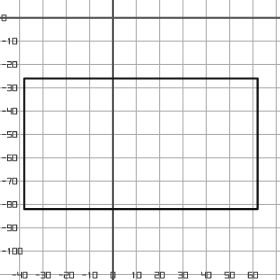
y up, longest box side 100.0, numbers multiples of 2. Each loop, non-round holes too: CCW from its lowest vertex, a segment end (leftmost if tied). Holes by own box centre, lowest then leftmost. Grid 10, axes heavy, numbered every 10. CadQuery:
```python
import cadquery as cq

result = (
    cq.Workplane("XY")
    .moveTo(-38.0, -82.0)
    .lineTo(62.0, -82.0)
    .lineTo(62.0, -26.0)
    .lineTo(-38.0, -26.0)
    .close()
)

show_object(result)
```